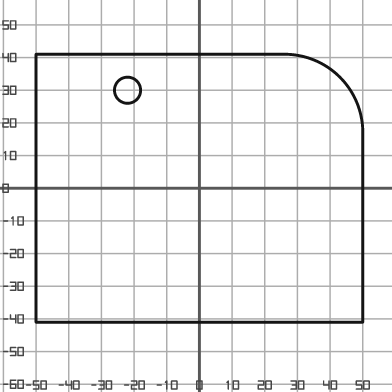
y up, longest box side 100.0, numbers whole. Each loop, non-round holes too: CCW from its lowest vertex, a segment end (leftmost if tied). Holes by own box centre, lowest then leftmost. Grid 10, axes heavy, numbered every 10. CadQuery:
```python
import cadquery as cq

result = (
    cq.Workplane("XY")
    .moveTo(-50.0, -41.0)
    .lineTo(50.0, -41.0)
    .lineTo(50.0, 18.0)
    .threePointArc((43.0, 34.0), (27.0, 41.0))
    .lineTo(-50.0, 41.0)
    .close()
    .moveTo(-22.0, 30.0)
    .circle(4.0)
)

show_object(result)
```